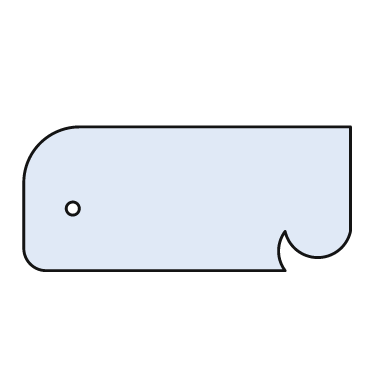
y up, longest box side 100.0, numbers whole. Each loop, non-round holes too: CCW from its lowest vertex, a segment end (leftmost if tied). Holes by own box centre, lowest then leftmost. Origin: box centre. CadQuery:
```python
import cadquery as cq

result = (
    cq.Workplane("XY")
    .moveTo(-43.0, -22.0)
    .lineTo(30.0, -22.0)
    .threePointArc((28.0, -16.0), (30.0, -10.0))
    .threePointArc((40.0, -18.0), (50.0, -10.0))
    .lineTo(50.0, 22.0)
    .lineTo(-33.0, 22.0)
    .threePointArc((-45.0, 17.0), (-50.0, 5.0))
    .lineTo(-50.0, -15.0)
    .threePointArc((-48.0, -20.0), (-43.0, -22.0))
    .close()
    .moveTo(-35.0, -3.0)
    .circle(2.0)
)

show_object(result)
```